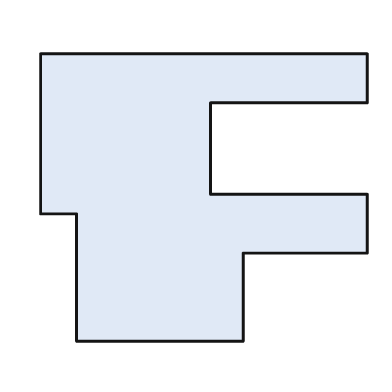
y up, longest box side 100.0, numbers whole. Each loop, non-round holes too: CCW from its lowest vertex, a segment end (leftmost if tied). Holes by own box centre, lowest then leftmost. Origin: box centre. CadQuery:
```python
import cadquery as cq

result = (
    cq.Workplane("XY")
    .moveTo(-39.0, -44.0)
    .lineTo(12.0, -44.0)
    .lineTo(12.0, -17.0)
    .lineTo(50.0, -17.0)
    .lineTo(50.0, 1.0)
    .lineTo(2.0, 1.0)
    .lineTo(2.0, 29.0)
    .lineTo(50.0, 29.0)
    .lineTo(50.0, 44.0)
    .lineTo(-50.0, 44.0)
    .lineTo(-50.0, -5.0)
    .lineTo(-39.0, -5.0)
    .close()
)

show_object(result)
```